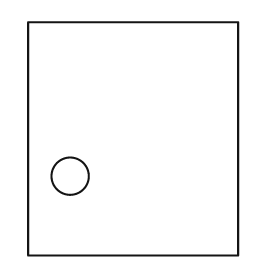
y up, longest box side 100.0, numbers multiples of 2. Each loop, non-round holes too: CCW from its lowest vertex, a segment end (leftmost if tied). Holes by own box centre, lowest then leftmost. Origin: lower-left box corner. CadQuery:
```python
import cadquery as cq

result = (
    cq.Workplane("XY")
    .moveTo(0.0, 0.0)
    .lineTo(90.0, 0.0)
    .lineTo(90.0, 100.0)
    .lineTo(0.0, 100.0)
    .close()
    .moveTo(18.0, 34.0)
    .circle(8.0)
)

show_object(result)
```